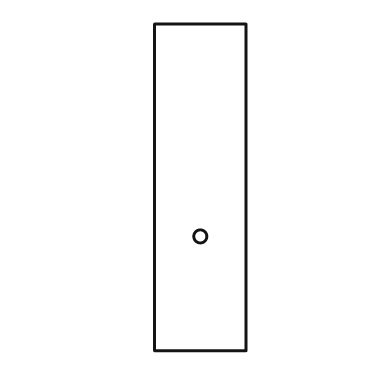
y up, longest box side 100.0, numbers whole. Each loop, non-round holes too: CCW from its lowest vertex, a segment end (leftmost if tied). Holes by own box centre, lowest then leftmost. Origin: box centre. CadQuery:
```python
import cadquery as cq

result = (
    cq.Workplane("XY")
    .moveTo(-14.0, -50.0)
    .lineTo(14.0, -50.0)
    .lineTo(14.0, 50.0)
    .lineTo(-14.0, 50.0)
    .close()
    .moveTo(0.0, -15.0)
    .circle(2.0)
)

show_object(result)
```